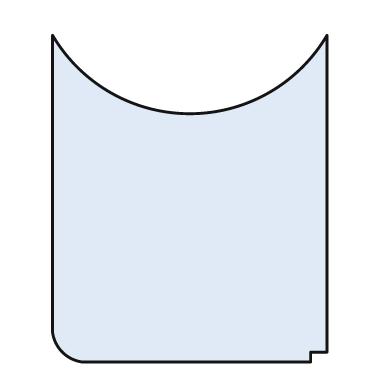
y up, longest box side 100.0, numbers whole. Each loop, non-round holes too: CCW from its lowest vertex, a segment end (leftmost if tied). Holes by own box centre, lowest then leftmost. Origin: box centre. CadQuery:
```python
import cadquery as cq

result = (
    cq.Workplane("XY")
    .moveTo(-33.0, -50.0)
    .lineTo(37.0, -50.0)
    .lineTo(37.0, -47.0)
    .lineTo(42.0, -47.0)
    .lineTo(42.0, 50.0)
    .threePointArc((0.0, 26.0), (-42.0, 50.0))
    .lineTo(-42.0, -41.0)
    .threePointArc((-39.0, -47.0), (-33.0, -50.0))
    .close()
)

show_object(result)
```